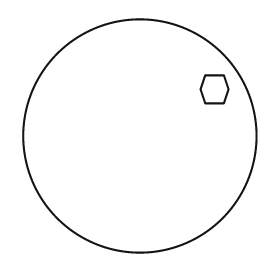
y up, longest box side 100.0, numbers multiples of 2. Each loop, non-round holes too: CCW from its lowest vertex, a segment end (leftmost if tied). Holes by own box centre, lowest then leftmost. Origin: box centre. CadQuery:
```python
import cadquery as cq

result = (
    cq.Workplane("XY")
    .moveTo(0.0, 0.0)
    .circle(50.0)
    .moveTo(28.0, 14.0)
    .lineTo(36.0, 14.0)
    .lineTo(38.0, 20.0)
    .lineTo(36.0, 26.0)
    .lineTo(28.0, 26.0)
    .lineTo(26.0, 20.0)
    .close()
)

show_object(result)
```